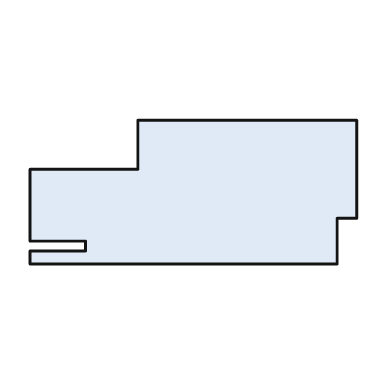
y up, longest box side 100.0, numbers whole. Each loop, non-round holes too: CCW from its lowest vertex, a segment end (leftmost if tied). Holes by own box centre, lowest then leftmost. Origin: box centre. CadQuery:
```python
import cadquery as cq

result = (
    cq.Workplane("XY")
    .moveTo(-50.0, -22.0)
    .lineTo(44.0, -22.0)
    .lineTo(44.0, -8.0)
    .lineTo(50.0, -8.0)
    .lineTo(50.0, 22.0)
    .lineTo(-17.0, 22.0)
    .lineTo(-17.0, 7.0)
    .lineTo(-50.0, 7.0)
    .lineTo(-50.0, -15.0)
    .lineTo(-33.0, -15.0)
    .lineTo(-33.0, -18.0)
    .lineTo(-50.0, -18.0)
    .close()
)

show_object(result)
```